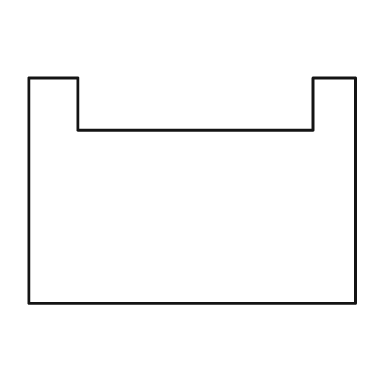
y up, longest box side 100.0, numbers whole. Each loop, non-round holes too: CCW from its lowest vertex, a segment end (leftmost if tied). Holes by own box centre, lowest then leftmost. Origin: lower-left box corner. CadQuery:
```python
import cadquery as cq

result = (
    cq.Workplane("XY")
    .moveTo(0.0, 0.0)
    .lineTo(100.0, 0.0)
    .lineTo(100.0, 69.0)
    .lineTo(87.0, 69.0)
    .lineTo(87.0, 53.0)
    .lineTo(15.0, 53.0)
    .lineTo(15.0, 69.0)
    .lineTo(0.0, 69.0)
    .close()
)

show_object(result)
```